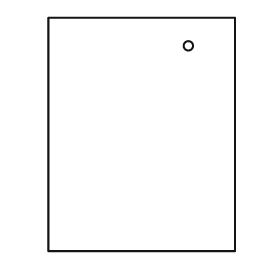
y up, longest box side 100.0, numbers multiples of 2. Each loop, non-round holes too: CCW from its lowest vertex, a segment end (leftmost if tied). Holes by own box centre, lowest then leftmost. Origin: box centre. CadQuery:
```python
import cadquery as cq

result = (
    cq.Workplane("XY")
    .moveTo(-40.0, -50.0)
    .lineTo(40.0, -50.0)
    .lineTo(40.0, 50.0)
    .lineTo(-40.0, 50.0)
    .close()
    .moveTo(20.0, 38.0)
    .circle(2.0)
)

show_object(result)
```